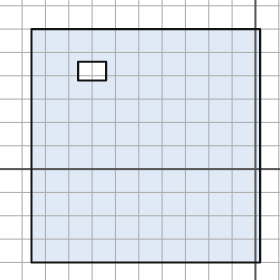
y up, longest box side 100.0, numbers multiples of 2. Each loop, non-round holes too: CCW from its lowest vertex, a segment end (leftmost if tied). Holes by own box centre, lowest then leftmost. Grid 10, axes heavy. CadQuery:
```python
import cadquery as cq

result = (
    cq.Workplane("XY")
    .moveTo(-96.0, -40.0)
    .lineTo(2.0, -40.0)
    .lineTo(2.0, 60.0)
    .lineTo(-96.0, 60.0)
    .close()
    .moveTo(-76.0, 38.0)
    .lineTo(-64.0, 38.0)
    .lineTo(-64.0, 46.0)
    .lineTo(-76.0, 46.0)
    .close()
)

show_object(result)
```